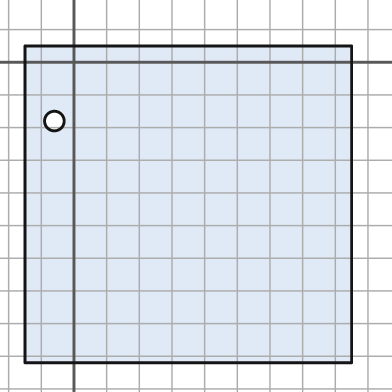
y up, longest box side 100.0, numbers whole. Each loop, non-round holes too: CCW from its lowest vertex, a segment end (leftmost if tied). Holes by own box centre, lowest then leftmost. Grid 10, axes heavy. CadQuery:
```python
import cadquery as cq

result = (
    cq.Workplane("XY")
    .moveTo(-15.0, -92.0)
    .lineTo(85.0, -92.0)
    .lineTo(85.0, 5.0)
    .lineTo(-15.0, 5.0)
    .close()
    .moveTo(-6.0, -18.0)
    .circle(3.0)
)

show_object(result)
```